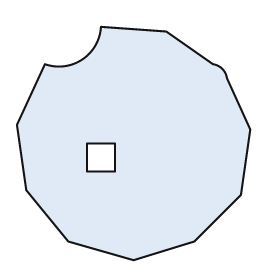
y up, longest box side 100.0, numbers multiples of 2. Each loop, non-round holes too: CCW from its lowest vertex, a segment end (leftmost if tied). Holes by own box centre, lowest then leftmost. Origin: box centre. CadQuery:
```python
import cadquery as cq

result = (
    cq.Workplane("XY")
    .moveTo(0.0, -50.0)
    .lineTo(26.0, -42.0)
    .lineTo(46.0, -22.0)
    .lineTo(50.0, 6.0)
    .lineTo(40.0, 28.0)
    .threePointArc((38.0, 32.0), (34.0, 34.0))
    .lineTo(14.0, 48.0)
    .lineTo(-14.0, 50.0)
    .threePointArc((-22.0, 36.0), (-38.0, 34.0))
    .lineTo(-50.0, 8.0)
    .lineTo(-46.0, -20.0)
    .lineTo(-28.0, -42.0)
    .close()
    .moveTo(-20.0, -12.0)
    .lineTo(-8.0, -12.0)
    .lineTo(-8.0, 0.0)
    .lineTo(-20.0, 0.0)
    .close()
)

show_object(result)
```